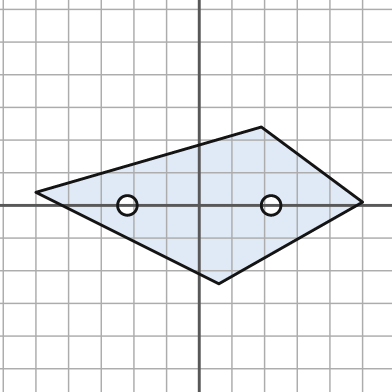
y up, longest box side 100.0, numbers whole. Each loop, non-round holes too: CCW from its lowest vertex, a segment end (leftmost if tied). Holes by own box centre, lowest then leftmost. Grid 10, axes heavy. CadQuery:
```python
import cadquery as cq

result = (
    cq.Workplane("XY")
    .moveTo(6.0, -24.0)
    .lineTo(50.0, 1.0)
    .lineTo(19.0, 24.0)
    .lineTo(-50.0, 4.0)
    .close()
    .moveTo(-22.0, 0.0)
    .circle(3.0)
    .moveTo(22.0, 0.0)
    .circle(3.0)
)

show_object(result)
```